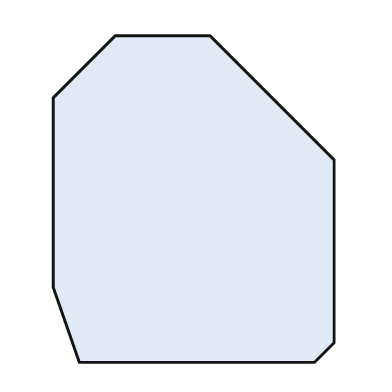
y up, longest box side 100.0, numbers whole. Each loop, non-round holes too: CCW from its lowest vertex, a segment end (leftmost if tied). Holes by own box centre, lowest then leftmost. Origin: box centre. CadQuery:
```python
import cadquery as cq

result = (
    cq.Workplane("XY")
    .moveTo(-35.0, -50.0)
    .lineTo(37.0, -50.0)
    .lineTo(43.0, -44.0)
    .lineTo(43.0, 12.0)
    .lineTo(5.0, 50.0)
    .lineTo(-24.0, 50.0)
    .lineTo(-43.0, 31.0)
    .lineTo(-43.0, -27.0)
    .close()
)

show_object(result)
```